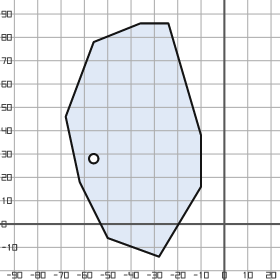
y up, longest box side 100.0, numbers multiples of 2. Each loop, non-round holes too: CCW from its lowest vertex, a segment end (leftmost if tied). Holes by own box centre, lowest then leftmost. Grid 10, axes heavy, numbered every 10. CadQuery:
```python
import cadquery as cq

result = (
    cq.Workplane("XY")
    .moveTo(-28.0, -14.0)
    .lineTo(-10.0, 16.0)
    .lineTo(-10.0, 38.0)
    .lineTo(-24.0, 86.0)
    .lineTo(-36.0, 86.0)
    .lineTo(-56.0, 78.0)
    .lineTo(-68.0, 46.0)
    .lineTo(-62.0, 18.0)
    .lineTo(-50.0, -6.0)
    .close()
    .moveTo(-56.0, 28.0)
    .circle(2.0)
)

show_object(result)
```